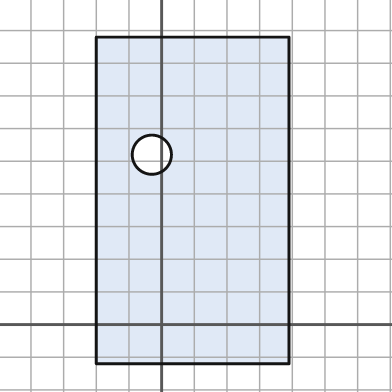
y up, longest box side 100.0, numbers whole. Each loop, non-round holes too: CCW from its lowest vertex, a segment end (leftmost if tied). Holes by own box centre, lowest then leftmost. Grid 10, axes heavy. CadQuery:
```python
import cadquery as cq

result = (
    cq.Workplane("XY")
    .moveTo(-20.0, -12.0)
    .lineTo(39.0, -12.0)
    .lineTo(39.0, 88.0)
    .lineTo(-20.0, 88.0)
    .close()
    .moveTo(-3.0, 52.0)
    .circle(6.0)
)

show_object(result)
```